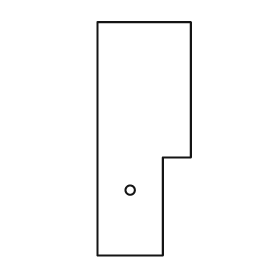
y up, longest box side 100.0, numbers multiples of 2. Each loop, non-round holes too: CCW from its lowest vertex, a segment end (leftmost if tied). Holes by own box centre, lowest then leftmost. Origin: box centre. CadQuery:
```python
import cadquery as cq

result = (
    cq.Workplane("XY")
    .moveTo(-20.0, -50.0)
    .lineTo(8.0, -50.0)
    .lineTo(8.0, -8.0)
    .lineTo(20.0, -8.0)
    .lineTo(20.0, 50.0)
    .lineTo(-20.0, 50.0)
    .close()
    .moveTo(-6.0, -22.0)
    .circle(2.0)
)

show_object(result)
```